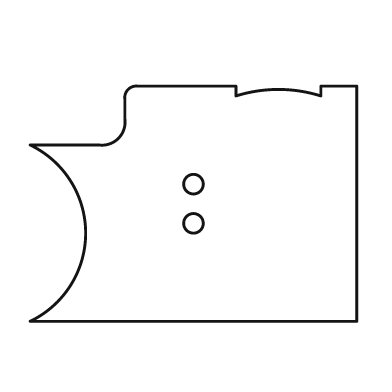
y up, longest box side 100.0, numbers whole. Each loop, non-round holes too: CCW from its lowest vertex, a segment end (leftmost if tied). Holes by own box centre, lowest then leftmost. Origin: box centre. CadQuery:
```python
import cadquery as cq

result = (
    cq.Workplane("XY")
    .moveTo(-50.0, -36.0)
    .lineTo(50.0, -36.0)
    .lineTo(50.0, 36.0)
    .lineTo(39.0, 36.0)
    .lineTo(39.0, 33.0)
    .threePointArc((26.0, 35.0), (13.0, 33.0))
    .lineTo(13.0, 36.0)
    .lineTo(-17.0, 36.0)
    .threePointArc((-20.0, 35.0), (-21.0, 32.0))
    .lineTo(-21.0, 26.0)
    .threePointArc((-23.0, 20.0), (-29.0, 18.0))
    .lineTo(-50.0, 18.0)
    .threePointArc((-33.0, -9.0), (-50.0, -36.0))
    .close()
    .moveTo(0.0, -6.0)
    .circle(3.0)
    .moveTo(0.0, 6.0)
    .circle(3.0)
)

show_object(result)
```